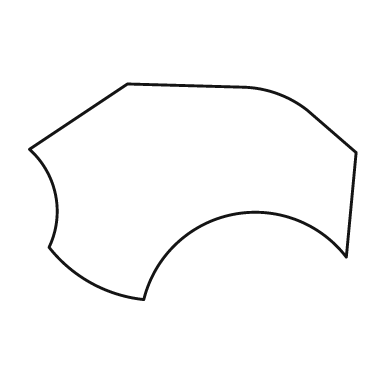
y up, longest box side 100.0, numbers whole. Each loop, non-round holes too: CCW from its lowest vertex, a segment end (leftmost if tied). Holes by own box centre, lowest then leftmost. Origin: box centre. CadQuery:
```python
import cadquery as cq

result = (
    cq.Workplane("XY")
    .moveTo(-15.0, -33.0)
    .threePointArc((12.0, -7.0), (47.0, -20.0))
    .lineTo(50.0, 12.0)
    .lineTo(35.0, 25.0)
    .threePointArc((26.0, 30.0), (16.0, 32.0))
    .lineTo(-20.0, 33.0)
    .lineTo(-50.0, 13.0)
    .threePointArc((-42.0, -1.0), (-44.0, -17.0))
    .threePointArc((-31.0, -28.0), (-15.0, -33.0))
    .close()
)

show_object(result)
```